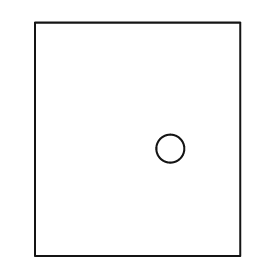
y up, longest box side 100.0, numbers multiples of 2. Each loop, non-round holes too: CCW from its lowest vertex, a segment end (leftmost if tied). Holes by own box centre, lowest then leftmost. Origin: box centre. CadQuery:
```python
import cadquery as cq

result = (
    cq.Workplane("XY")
    .moveTo(-44.0, -50.0)
    .lineTo(44.0, -50.0)
    .lineTo(44.0, 50.0)
    .lineTo(-44.0, 50.0)
    .close()
    .moveTo(14.0, -4.0)
    .circle(6.0)
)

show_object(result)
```